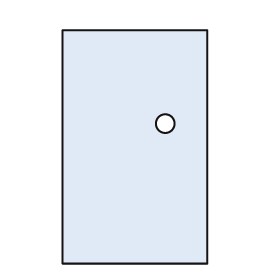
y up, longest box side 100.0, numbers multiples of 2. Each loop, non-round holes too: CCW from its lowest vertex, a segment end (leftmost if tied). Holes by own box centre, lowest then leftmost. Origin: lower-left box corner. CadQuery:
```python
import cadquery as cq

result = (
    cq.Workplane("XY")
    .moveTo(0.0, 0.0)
    .lineTo(62.0, 0.0)
    .lineTo(62.0, 100.0)
    .lineTo(0.0, 100.0)
    .close()
    .moveTo(44.0, 60.0)
    .circle(4.0)
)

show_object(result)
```